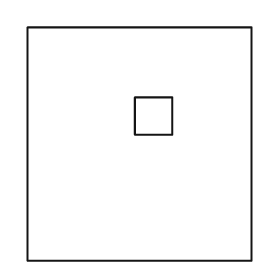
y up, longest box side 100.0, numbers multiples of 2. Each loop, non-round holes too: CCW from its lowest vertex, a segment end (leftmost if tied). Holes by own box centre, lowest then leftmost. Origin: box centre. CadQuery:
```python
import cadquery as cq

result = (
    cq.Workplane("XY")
    .moveTo(-48.0, -50.0)
    .lineTo(48.0, -50.0)
    .lineTo(48.0, 50.0)
    .lineTo(-48.0, 50.0)
    .close()
    .moveTo(-2.0, 4.0)
    .lineTo(14.0, 4.0)
    .lineTo(14.0, 20.0)
    .lineTo(-2.0, 20.0)
    .close()
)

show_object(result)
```